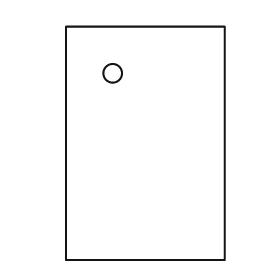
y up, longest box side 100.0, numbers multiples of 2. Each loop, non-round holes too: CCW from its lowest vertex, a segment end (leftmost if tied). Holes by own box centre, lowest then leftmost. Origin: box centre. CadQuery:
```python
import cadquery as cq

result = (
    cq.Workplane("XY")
    .moveTo(-34.0, -50.0)
    .lineTo(34.0, -50.0)
    .lineTo(34.0, 50.0)
    .lineTo(-34.0, 50.0)
    .close()
    .moveTo(-14.0, 30.0)
    .circle(4.0)
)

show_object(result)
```